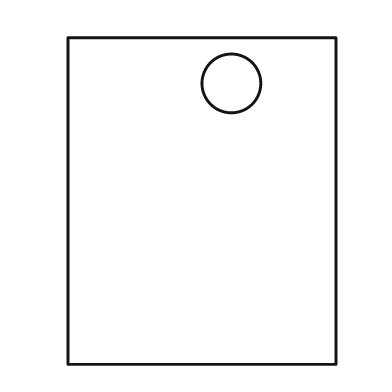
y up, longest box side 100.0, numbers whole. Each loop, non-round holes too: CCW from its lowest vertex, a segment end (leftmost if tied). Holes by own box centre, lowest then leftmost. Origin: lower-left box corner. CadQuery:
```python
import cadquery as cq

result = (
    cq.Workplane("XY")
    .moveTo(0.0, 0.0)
    .lineTo(82.0, 0.0)
    .lineTo(82.0, 100.0)
    .lineTo(0.0, 100.0)
    .close()
    .moveTo(50.0, 86.0)
    .circle(9.0)
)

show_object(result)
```